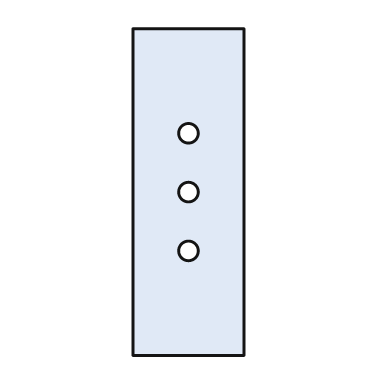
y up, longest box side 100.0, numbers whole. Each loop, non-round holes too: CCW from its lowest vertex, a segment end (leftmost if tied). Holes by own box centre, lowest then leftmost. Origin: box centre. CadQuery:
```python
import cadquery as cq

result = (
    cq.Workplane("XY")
    .moveTo(-17.0, -50.0)
    .lineTo(17.0, -50.0)
    .lineTo(17.0, 50.0)
    .lineTo(-17.0, 50.0)
    .close()
    .moveTo(0.0, -18.0)
    .circle(3.0)
    .moveTo(0.0, 0.0)
    .circle(3.0)
    .moveTo(0.0, 18.0)
    .circle(3.0)
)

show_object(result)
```